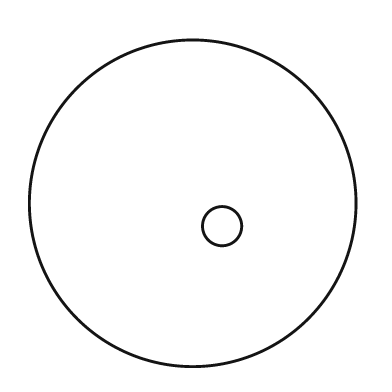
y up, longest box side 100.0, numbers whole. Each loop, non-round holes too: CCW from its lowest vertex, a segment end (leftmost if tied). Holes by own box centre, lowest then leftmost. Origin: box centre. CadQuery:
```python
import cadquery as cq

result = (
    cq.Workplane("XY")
    .moveTo(0.0, 0.0)
    .circle(50.0)
    .moveTo(9.0, -7.0)
    .circle(6.0)
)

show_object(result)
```